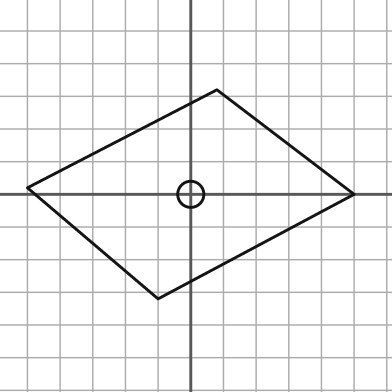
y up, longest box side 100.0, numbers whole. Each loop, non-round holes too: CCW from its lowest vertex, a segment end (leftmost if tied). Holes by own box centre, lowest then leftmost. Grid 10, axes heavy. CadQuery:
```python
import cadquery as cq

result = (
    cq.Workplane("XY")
    .moveTo(-10.0, -32.0)
    .lineTo(50.0, 0.0)
    .lineTo(8.0, 32.0)
    .lineTo(-50.0, 2.0)
    .close()
    .moveTo(0.0, 0.0)
    .circle(4.0)
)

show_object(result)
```